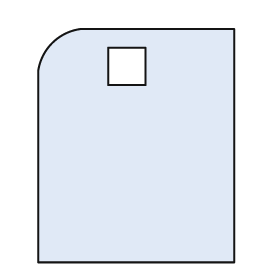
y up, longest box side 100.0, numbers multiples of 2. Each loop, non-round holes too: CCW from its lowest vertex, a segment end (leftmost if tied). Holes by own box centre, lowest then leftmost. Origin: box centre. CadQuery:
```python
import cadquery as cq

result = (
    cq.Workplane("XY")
    .moveTo(-42.0, -50.0)
    .lineTo(42.0, -50.0)
    .lineTo(42.0, 50.0)
    .lineTo(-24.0, 50.0)
    .threePointArc((-36.0, 44.0), (-42.0, 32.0))
    .close()
    .moveTo(-12.0, 26.0)
    .lineTo(4.0, 26.0)
    .lineTo(4.0, 42.0)
    .lineTo(-12.0, 42.0)
    .close()
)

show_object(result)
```